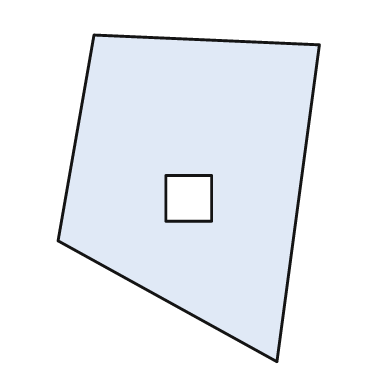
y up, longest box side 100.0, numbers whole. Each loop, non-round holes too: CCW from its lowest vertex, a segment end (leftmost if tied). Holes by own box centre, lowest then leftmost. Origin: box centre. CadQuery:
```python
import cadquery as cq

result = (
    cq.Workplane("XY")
    .moveTo(27.0, -50.0)
    .lineTo(40.0, 47.0)
    .lineTo(-29.0, 50.0)
    .lineTo(-40.0, -13.0)
    .close()
    .moveTo(-7.0, -7.0)
    .lineTo(7.0, -7.0)
    .lineTo(7.0, 7.0)
    .lineTo(-7.0, 7.0)
    .close()
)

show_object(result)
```